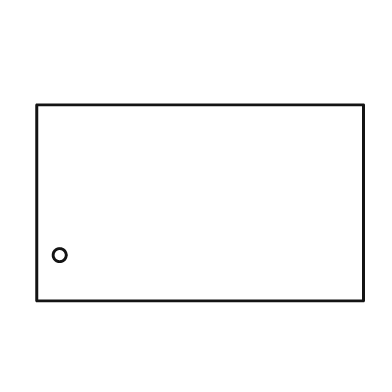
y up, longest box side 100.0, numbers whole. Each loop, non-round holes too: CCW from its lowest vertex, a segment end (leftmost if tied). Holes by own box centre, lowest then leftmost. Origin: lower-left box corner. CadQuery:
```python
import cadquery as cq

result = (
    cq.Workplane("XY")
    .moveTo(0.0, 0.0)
    .lineTo(100.0, 0.0)
    .lineTo(100.0, 60.0)
    .lineTo(0.0, 60.0)
    .close()
    .moveTo(7.0, 14.0)
    .circle(2.0)
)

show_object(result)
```